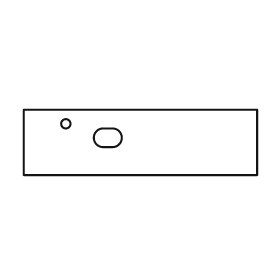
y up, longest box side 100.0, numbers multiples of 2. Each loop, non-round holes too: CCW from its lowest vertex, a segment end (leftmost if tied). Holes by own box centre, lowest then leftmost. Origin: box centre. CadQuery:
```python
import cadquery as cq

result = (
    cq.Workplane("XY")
    .moveTo(-50.0, -14.0)
    .lineTo(50.0, -14.0)
    .lineTo(50.0, 14.0)
    .lineTo(-50.0, 14.0)
    .close()
    .moveTo(-16.0, -2.0)
    .lineTo(-12.0, -2.0)
    .threePointArc((-8.0, 2.0), (-12.0, 6.0))
    .lineTo(-16.0, 6.0)
    .threePointArc((-20.0, 2.0), (-16.0, -2.0))
    .close()
    .moveTo(-32.0, 8.0)
    .circle(2.0)
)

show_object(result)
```